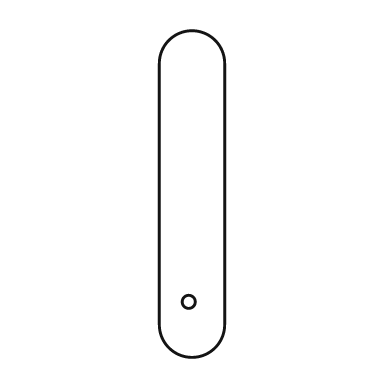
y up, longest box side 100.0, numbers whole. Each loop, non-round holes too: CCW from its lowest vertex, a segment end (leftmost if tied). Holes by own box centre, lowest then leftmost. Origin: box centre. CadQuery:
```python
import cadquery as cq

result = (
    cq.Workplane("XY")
    .moveTo(-10.0, -40.0)
    .threePointArc((0.0, -50.0), (10.0, -40.0))
    .lineTo(10.0, 40.0)
    .threePointArc((0.0, 50.0), (-10.0, 40.0))
    .close()
    .moveTo(-1.0, -33.0)
    .circle(2.0)
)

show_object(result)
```